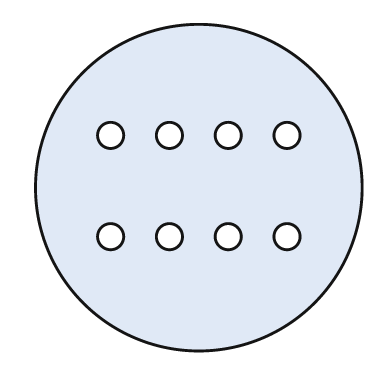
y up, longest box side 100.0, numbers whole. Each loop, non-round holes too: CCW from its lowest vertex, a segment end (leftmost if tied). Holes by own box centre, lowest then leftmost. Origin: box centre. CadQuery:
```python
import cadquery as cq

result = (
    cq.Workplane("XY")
    .moveTo(0.0, 0.0)
    .circle(50.0)
    .moveTo(-27.0, -15.0)
    .circle(4.0)
    .moveTo(-9.0, -15.0)
    .circle(4.0)
    .moveTo(9.0, -15.0)
    .circle(4.0)
    .moveTo(27.0, -15.0)
    .circle(4.0)
    .moveTo(-27.0, 16.0)
    .circle(4.0)
    .moveTo(-9.0, 16.0)
    .circle(4.0)
    .moveTo(9.0, 16.0)
    .circle(4.0)
    .moveTo(27.0, 16.0)
    .circle(4.0)
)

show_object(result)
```